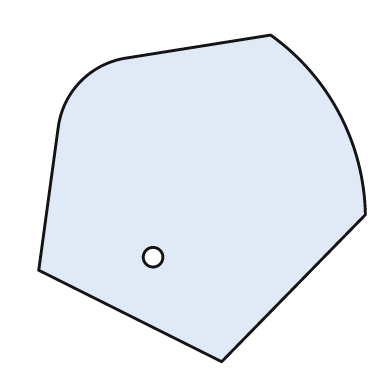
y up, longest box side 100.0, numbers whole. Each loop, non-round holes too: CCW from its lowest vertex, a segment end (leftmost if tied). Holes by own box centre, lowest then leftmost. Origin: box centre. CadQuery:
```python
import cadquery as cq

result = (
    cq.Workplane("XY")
    .moveTo(6.0, -50.0)
    .lineTo(50.0, -5.0)
    .threePointArc((42.0, 26.0), (21.0, 50.0))
    .lineTo(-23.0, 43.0)
    .threePointArc((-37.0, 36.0), (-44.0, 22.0))
    .lineTo(-50.0, -22.0)
    .close()
    .moveTo(-15.0, -18.0)
    .circle(3.0)
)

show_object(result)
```